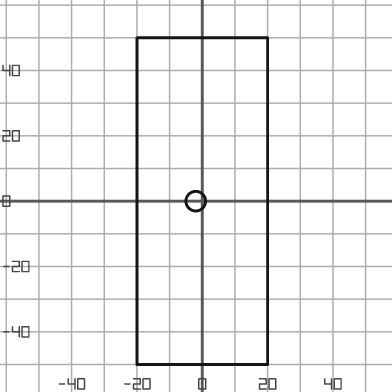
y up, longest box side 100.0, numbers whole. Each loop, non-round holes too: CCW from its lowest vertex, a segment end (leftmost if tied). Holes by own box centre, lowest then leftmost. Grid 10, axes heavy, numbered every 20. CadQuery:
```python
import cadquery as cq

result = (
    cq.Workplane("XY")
    .moveTo(-20.0, -50.0)
    .lineTo(20.0, -50.0)
    .lineTo(20.0, 50.0)
    .lineTo(-20.0, 50.0)
    .close()
    .moveTo(-2.0, 0.0)
    .circle(3.0)
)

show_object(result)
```